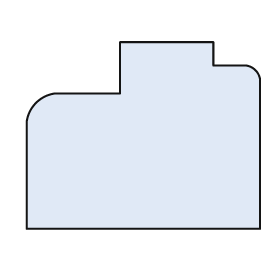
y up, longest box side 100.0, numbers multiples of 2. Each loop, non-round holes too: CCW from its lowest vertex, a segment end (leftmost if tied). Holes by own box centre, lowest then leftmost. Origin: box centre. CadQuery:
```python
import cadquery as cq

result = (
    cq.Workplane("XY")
    .moveTo(-50.0, -40.0)
    .lineTo(50.0, -40.0)
    .lineTo(50.0, 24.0)
    .threePointArc((48.0, 28.0), (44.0, 30.0))
    .lineTo(30.0, 30.0)
    .lineTo(30.0, 40.0)
    .lineTo(-10.0, 40.0)
    .lineTo(-10.0, 18.0)
    .lineTo(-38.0, 18.0)
    .threePointArc((-46.0, 14.0), (-50.0, 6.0))
    .close()
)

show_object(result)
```